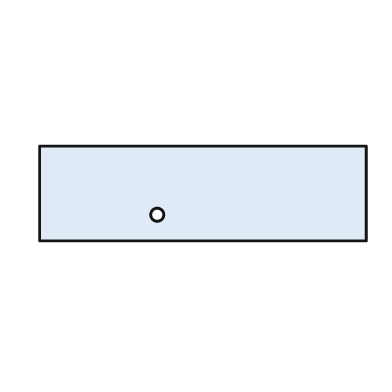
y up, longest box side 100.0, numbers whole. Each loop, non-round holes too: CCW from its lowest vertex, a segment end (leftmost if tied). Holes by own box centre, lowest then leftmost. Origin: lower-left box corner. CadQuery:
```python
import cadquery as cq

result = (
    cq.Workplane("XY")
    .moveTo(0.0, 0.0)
    .lineTo(100.0, 0.0)
    .lineTo(100.0, 29.0)
    .lineTo(0.0, 29.0)
    .close()
    .moveTo(36.0, 8.0)
    .circle(2.0)
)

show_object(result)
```